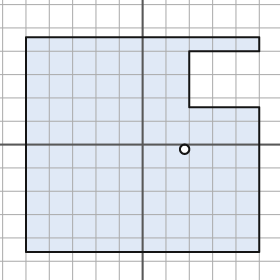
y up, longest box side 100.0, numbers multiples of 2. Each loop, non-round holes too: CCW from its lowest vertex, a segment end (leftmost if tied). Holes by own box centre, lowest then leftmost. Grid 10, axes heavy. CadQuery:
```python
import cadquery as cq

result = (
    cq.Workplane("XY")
    .moveTo(-50.0, -46.0)
    .lineTo(50.0, -46.0)
    .lineTo(50.0, 16.0)
    .lineTo(20.0, 16.0)
    .lineTo(20.0, 40.0)
    .lineTo(50.0, 40.0)
    .lineTo(50.0, 46.0)
    .lineTo(-50.0, 46.0)
    .close()
    .moveTo(18.0, -2.0)
    .circle(2.0)
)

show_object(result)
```